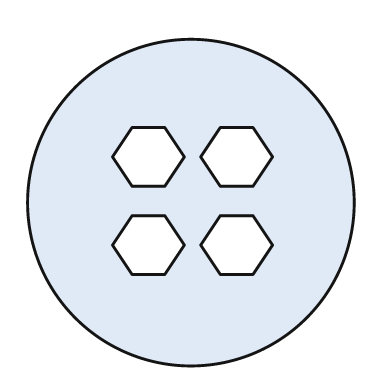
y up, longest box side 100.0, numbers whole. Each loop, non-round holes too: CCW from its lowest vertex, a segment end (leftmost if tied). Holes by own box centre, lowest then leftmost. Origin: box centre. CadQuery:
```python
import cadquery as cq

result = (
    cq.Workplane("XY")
    .moveTo(0.0, 0.0)
    .circle(50.0)
    .moveTo(-18.0, -22.0)
    .lineTo(-8.0, -22.0)
    .lineTo(-2.0, -13.0)
    .lineTo(-8.0, -4.0)
    .lineTo(-18.0, -4.0)
    .lineTo(-24.0, -13.0)
    .close()
    .moveTo(9.0, -22.0)
    .lineTo(19.0, -22.0)
    .lineTo(25.0, -13.0)
    .lineTo(19.0, -4.0)
    .lineTo(9.0, -4.0)
    .lineTo(3.0, -13.0)
    .close()
    .moveTo(-18.0, 5.0)
    .lineTo(-8.0, 5.0)
    .lineTo(-2.0, 14.0)
    .lineTo(-8.0, 23.0)
    .lineTo(-18.0, 23.0)
    .lineTo(-24.0, 14.0)
    .close()
    .moveTo(9.0, 5.0)
    .lineTo(19.0, 5.0)
    .lineTo(25.0, 14.0)
    .lineTo(19.0, 23.0)
    .lineTo(9.0, 23.0)
    .lineTo(3.0, 14.0)
    .close()
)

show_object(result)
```